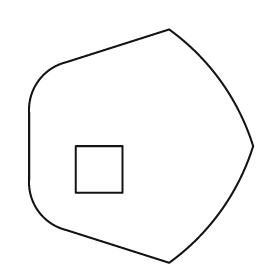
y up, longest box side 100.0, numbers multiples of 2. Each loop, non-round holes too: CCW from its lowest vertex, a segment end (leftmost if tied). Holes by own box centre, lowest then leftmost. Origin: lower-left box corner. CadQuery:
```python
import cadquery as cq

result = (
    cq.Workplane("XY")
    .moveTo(60.0, 0.0)
    .threePointArc((82.0, 22.0), (96.0, 50.0))
    .threePointArc((82.0, 78.0), (60.0, 100.0))
    .lineTo(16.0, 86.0)
    .threePointArc((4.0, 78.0), (0.0, 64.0))
    .lineTo(0.0, 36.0)
    .threePointArc((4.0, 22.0), (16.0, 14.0))
    .close()
    .moveTo(20.0, 30.0)
    .lineTo(40.0, 30.0)
    .lineTo(40.0, 50.0)
    .lineTo(20.0, 50.0)
    .close()
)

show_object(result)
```